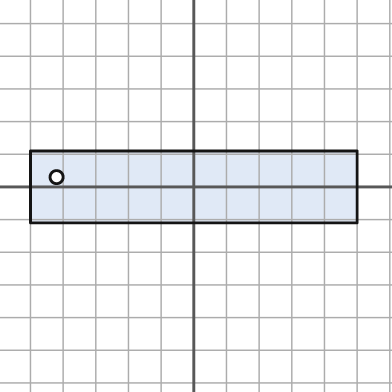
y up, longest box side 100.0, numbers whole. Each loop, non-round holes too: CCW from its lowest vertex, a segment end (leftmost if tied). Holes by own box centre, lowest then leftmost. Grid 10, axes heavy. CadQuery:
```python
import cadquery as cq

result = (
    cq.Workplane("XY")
    .moveTo(-50.0, -11.0)
    .lineTo(50.0, -11.0)
    .lineTo(50.0, 11.0)
    .lineTo(-50.0, 11.0)
    .close()
    .moveTo(-42.0, 3.0)
    .circle(2.0)
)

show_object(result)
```